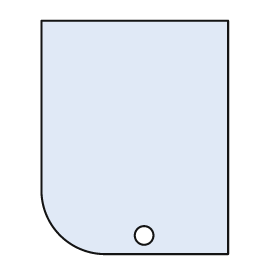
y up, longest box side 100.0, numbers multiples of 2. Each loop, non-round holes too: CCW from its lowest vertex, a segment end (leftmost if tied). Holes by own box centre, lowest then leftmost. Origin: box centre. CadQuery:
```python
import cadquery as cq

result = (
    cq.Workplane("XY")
    .moveTo(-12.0, -50.0)
    .lineTo(40.0, -50.0)
    .lineTo(40.0, 50.0)
    .lineTo(-40.0, 50.0)
    .lineTo(-40.0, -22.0)
    .threePointArc((-32.0, -42.0), (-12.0, -50.0))
    .close()
    .moveTo(4.0, -42.0)
    .circle(4.0)
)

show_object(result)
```